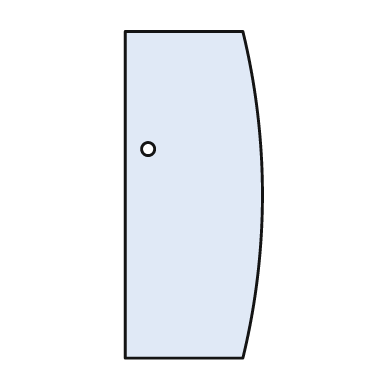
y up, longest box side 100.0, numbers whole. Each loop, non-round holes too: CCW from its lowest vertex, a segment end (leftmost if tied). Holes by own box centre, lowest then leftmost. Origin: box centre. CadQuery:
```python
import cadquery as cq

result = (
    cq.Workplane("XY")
    .moveTo(-21.0, -50.0)
    .lineTo(15.0, -50.0)
    .threePointArc((21.0, 0.0), (15.0, 50.0))
    .lineTo(-21.0, 50.0)
    .close()
    .moveTo(-14.0, 14.0)
    .circle(2.0)
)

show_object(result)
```